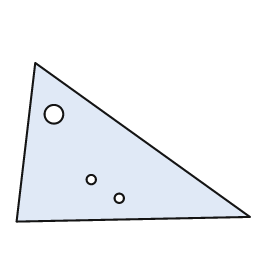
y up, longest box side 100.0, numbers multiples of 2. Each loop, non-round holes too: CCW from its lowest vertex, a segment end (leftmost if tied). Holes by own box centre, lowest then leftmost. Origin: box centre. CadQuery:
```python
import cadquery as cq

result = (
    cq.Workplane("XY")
    .moveTo(-50.0, -34.0)
    .lineTo(50.0, -32.0)
    .lineTo(-42.0, 34.0)
    .close()
    .moveTo(-6.0, -24.0)
    .circle(2.0)
    .moveTo(-18.0, -16.0)
    .circle(2.0)
    .moveTo(-34.0, 12.0)
    .circle(4.0)
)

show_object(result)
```